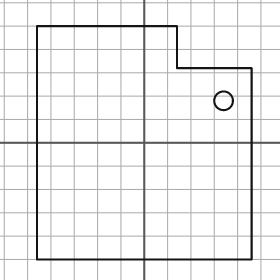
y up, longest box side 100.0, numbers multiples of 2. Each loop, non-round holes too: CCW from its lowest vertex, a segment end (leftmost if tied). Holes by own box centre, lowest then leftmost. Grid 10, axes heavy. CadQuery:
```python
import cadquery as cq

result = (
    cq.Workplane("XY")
    .moveTo(-46.0, -50.0)
    .lineTo(46.0, -50.0)
    .lineTo(46.0, 32.0)
    .lineTo(14.0, 32.0)
    .lineTo(14.0, 50.0)
    .lineTo(-46.0, 50.0)
    .close()
    .moveTo(34.0, 18.0)
    .circle(4.0)
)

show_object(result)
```